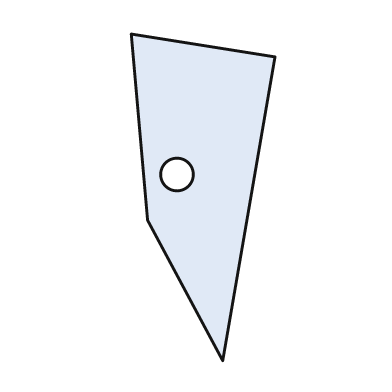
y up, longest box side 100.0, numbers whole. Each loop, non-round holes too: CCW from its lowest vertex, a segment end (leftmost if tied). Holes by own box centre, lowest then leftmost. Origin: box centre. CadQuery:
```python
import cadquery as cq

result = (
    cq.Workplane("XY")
    .moveTo(6.0, -50.0)
    .lineTo(22.0, 43.0)
    .lineTo(-22.0, 50.0)
    .lineTo(-17.0, -7.0)
    .close()
    .moveTo(-8.0, 7.0)
    .circle(5.0)
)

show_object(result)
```